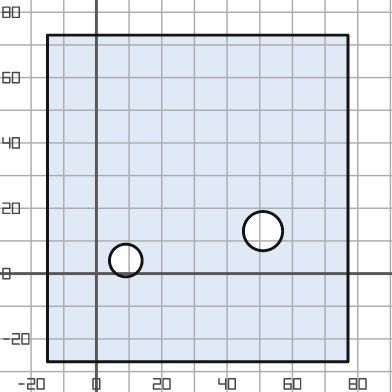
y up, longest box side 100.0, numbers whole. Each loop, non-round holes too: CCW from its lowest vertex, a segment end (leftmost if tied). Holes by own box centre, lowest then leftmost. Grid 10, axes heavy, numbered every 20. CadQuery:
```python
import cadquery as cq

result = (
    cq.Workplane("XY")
    .moveTo(-15.0, -27.0)
    .lineTo(77.0, -27.0)
    .lineTo(77.0, 73.0)
    .lineTo(-15.0, 73.0)
    .close()
    .moveTo(9.0, 4.0)
    .circle(5.0)
    .moveTo(51.0, 13.0)
    .circle(6.0)
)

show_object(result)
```